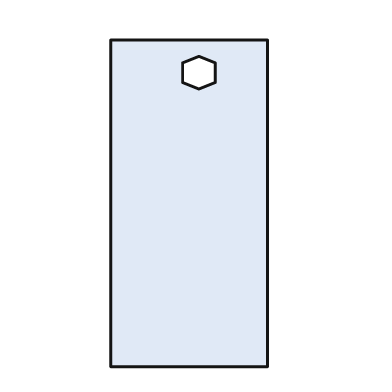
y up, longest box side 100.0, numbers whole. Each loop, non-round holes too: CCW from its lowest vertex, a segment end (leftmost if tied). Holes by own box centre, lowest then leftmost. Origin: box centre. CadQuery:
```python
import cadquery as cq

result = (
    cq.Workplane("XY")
    .moveTo(-24.0, -50.0)
    .lineTo(24.0, -50.0)
    .lineTo(24.0, 50.0)
    .lineTo(-24.0, 50.0)
    .close()
    .moveTo(3.0, 35.0)
    .lineTo(8.0, 37.0)
    .lineTo(8.0, 43.0)
    .lineTo(3.0, 45.0)
    .lineTo(-2.0, 43.0)
    .lineTo(-2.0, 37.0)
    .close()
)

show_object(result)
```